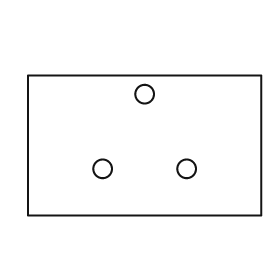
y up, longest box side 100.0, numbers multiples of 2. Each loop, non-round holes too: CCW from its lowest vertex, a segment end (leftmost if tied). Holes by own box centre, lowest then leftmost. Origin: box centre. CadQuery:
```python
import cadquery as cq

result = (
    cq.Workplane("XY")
    .moveTo(-50.0, -30.0)
    .lineTo(50.0, -30.0)
    .lineTo(50.0, 30.0)
    .lineTo(-50.0, 30.0)
    .close()
    .moveTo(-18.0, -10.0)
    .circle(4.0)
    .moveTo(18.0, -10.0)
    .circle(4.0)
    .moveTo(0.0, 22.0)
    .circle(4.0)
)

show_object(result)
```